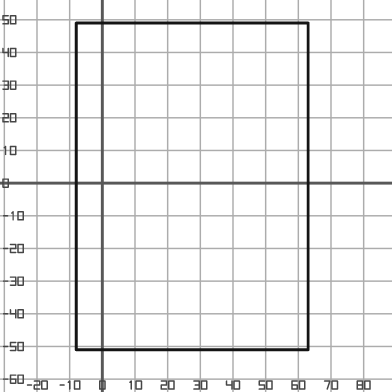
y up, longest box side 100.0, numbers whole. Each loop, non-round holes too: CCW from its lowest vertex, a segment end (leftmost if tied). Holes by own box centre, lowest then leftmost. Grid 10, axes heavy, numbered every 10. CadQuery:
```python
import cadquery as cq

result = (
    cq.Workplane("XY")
    .moveTo(-8.0, -51.0)
    .lineTo(63.0, -51.0)
    .lineTo(63.0, 49.0)
    .lineTo(-8.0, 49.0)
    .close()
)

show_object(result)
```